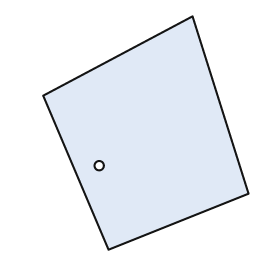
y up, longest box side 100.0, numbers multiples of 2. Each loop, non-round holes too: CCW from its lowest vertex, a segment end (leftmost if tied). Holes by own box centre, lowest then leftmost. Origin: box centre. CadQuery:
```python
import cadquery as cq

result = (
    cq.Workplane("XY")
    .moveTo(-16.0, -50.0)
    .lineTo(44.0, -26.0)
    .lineTo(20.0, 50.0)
    .lineTo(-44.0, 16.0)
    .close()
    .moveTo(-20.0, -14.0)
    .circle(2.0)
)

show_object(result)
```